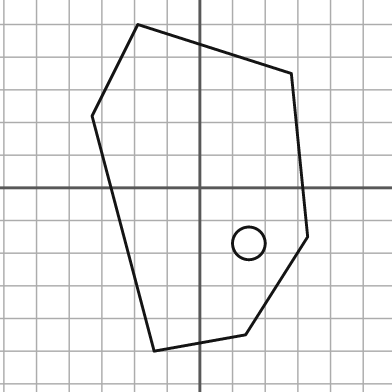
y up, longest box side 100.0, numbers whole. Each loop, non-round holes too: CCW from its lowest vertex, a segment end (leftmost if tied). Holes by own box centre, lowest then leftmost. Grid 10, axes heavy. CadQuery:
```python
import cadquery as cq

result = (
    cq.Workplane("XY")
    .moveTo(-14.0, -50.0)
    .lineTo(14.0, -45.0)
    .lineTo(33.0, -15.0)
    .lineTo(28.0, 35.0)
    .lineTo(-19.0, 50.0)
    .lineTo(-33.0, 22.0)
    .close()
    .moveTo(15.0, -17.0)
    .circle(5.0)
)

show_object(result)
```